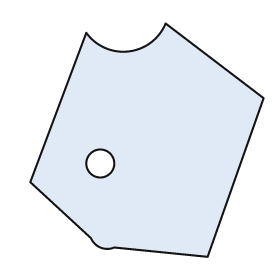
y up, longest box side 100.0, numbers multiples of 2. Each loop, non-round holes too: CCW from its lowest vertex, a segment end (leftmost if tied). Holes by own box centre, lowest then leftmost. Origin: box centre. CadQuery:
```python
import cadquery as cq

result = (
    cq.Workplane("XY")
    .moveTo(26.0, -50.0)
    .lineTo(50.0, 18.0)
    .lineTo(8.0, 50.0)
    .threePointArc((-8.0, 38.0), (-26.0, 46.0))
    .lineTo(-50.0, -18.0)
    .lineTo(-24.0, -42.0)
    .threePointArc((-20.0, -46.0), (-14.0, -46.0))
    .close()
    .moveTo(-20.0, -10.0)
    .circle(6.0)
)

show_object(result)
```